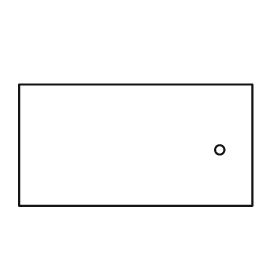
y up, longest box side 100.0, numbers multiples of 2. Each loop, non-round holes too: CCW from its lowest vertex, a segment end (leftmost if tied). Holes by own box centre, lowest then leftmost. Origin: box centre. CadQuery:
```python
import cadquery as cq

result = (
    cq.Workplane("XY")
    .moveTo(-50.0, -26.0)
    .lineTo(50.0, -26.0)
    .lineTo(50.0, 26.0)
    .lineTo(-50.0, 26.0)
    .close()
    .moveTo(36.0, -2.0)
    .circle(2.0)
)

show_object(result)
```